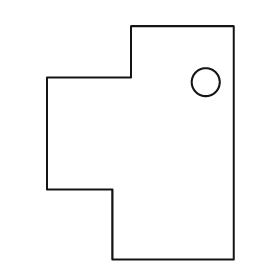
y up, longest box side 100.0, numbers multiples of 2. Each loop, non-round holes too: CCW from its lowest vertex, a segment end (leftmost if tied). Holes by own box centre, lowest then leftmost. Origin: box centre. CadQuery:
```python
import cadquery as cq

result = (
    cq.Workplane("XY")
    .moveTo(-12.0, -50.0)
    .lineTo(40.0, -50.0)
    .lineTo(40.0, 50.0)
    .lineTo(-4.0, 50.0)
    .lineTo(-4.0, 28.0)
    .lineTo(-40.0, 28.0)
    .lineTo(-40.0, -20.0)
    .lineTo(-12.0, -20.0)
    .close()
    .moveTo(28.0, 26.0)
    .circle(6.0)
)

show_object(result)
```